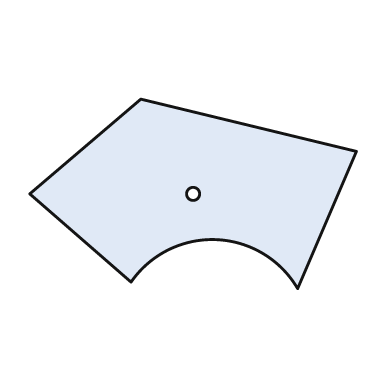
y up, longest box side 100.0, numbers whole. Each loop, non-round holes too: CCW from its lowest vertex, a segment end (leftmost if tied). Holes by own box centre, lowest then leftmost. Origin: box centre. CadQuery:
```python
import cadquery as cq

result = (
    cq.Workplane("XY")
    .moveTo(32.0, -29.0)
    .lineTo(50.0, 13.0)
    .lineTo(-16.0, 29.0)
    .lineTo(-50.0, 0.0)
    .lineTo(-19.0, -27.0)
    .threePointArc((7.0, -14.0), (32.0, -29.0))
    .close()
    .moveTo(0.0, 0.0)
    .circle(2.0)
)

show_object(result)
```